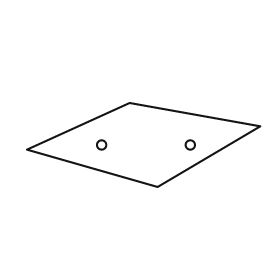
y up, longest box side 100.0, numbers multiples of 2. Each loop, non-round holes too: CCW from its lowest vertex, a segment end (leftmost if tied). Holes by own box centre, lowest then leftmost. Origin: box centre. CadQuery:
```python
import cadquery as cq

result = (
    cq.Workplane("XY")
    .moveTo(6.0, -18.0)
    .lineTo(50.0, 8.0)
    .lineTo(-6.0, 18.0)
    .lineTo(-50.0, -2.0)
    .close()
    .moveTo(-18.0, 0.0)
    .circle(2.0)
    .moveTo(20.0, 0.0)
    .circle(2.0)
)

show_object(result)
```